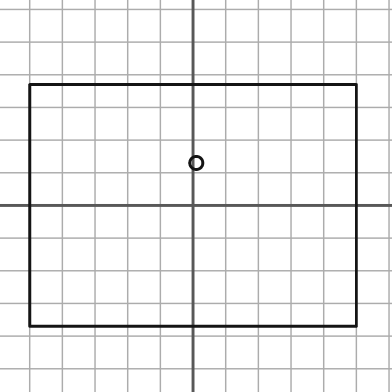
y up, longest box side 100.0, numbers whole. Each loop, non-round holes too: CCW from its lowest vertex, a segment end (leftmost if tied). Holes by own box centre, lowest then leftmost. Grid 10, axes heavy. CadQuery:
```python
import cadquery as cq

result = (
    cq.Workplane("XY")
    .moveTo(-50.0, -37.0)
    .lineTo(50.0, -37.0)
    .lineTo(50.0, 37.0)
    .lineTo(-50.0, 37.0)
    .close()
    .moveTo(1.0, 13.0)
    .circle(2.0)
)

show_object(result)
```